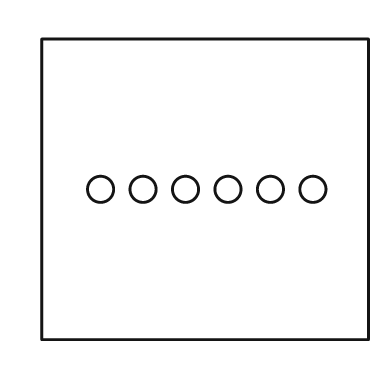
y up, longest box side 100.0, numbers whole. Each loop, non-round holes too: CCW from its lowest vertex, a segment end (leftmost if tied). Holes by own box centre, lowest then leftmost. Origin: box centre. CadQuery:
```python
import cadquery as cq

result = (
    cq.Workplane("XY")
    .moveTo(-50.0, -46.0)
    .lineTo(50.0, -46.0)
    .lineTo(50.0, 46.0)
    .lineTo(-50.0, 46.0)
    .close()
    .moveTo(-32.0, 0.0)
    .circle(4.0)
    .moveTo(-19.0, 0.0)
    .circle(4.0)
    .moveTo(-6.0, 0.0)
    .circle(4.0)
    .moveTo(7.0, 0.0)
    .circle(4.0)
    .moveTo(20.0, 0.0)
    .circle(4.0)
    .moveTo(33.0, 0.0)
    .circle(4.0)
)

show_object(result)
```